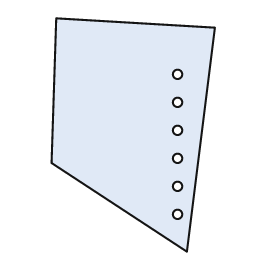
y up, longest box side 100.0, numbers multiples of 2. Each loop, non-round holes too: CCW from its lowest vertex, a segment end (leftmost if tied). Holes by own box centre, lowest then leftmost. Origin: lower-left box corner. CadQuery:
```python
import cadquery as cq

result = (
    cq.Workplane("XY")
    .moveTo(58.0, 0.0)
    .lineTo(70.0, 96.0)
    .lineTo(2.0, 100.0)
    .lineTo(0.0, 38.0)
    .close()
    .moveTo(54.0, 16.0)
    .circle(2.0)
    .moveTo(54.0, 28.0)
    .circle(2.0)
    .moveTo(54.0, 40.0)
    .circle(2.0)
    .moveTo(54.0, 52.0)
    .circle(2.0)
    .moveTo(54.0, 64.0)
    .circle(2.0)
    .moveTo(54.0, 76.0)
    .circle(2.0)
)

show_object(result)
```